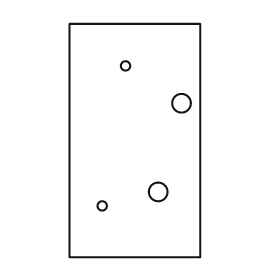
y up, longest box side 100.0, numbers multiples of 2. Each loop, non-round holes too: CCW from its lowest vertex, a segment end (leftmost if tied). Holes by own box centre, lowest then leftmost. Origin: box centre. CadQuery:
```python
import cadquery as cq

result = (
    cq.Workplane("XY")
    .moveTo(-28.0, -50.0)
    .lineTo(28.0, -50.0)
    .lineTo(28.0, 50.0)
    .lineTo(-28.0, 50.0)
    .close()
    .moveTo(-14.0, -28.0)
    .circle(2.0)
    .moveTo(10.0, -22.0)
    .circle(4.0)
    .moveTo(20.0, 16.0)
    .circle(4.0)
    .moveTo(-4.0, 32.0)
    .circle(2.0)
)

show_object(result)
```